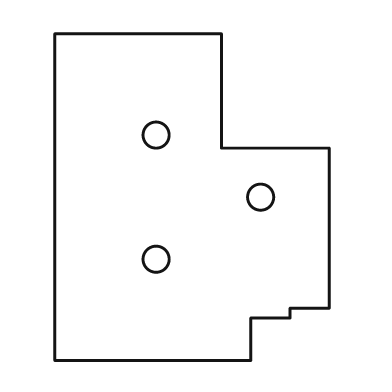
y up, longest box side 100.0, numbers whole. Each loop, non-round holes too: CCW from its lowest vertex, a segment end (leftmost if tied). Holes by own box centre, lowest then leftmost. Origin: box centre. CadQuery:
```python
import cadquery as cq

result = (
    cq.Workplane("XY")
    .moveTo(-42.0, -50.0)
    .lineTo(18.0, -50.0)
    .lineTo(18.0, -37.0)
    .lineTo(30.0, -37.0)
    .lineTo(30.0, -34.0)
    .lineTo(42.0, -34.0)
    .lineTo(42.0, 15.0)
    .lineTo(9.0, 15.0)
    .lineTo(9.0, 50.0)
    .lineTo(-42.0, 50.0)
    .close()
    .moveTo(-11.0, -19.0)
    .circle(4.0)
    .moveTo(21.0, 0.0)
    .circle(4.0)
    .moveTo(-11.0, 19.0)
    .circle(4.0)
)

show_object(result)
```